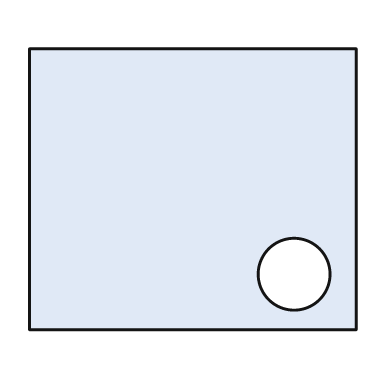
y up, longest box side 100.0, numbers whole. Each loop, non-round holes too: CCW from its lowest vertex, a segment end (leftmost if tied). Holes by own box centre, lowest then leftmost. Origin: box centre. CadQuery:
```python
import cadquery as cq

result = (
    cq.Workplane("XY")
    .moveTo(-50.0, -43.0)
    .lineTo(50.0, -43.0)
    .lineTo(50.0, 43.0)
    .lineTo(-50.0, 43.0)
    .close()
    .moveTo(31.0, -26.0)
    .circle(11.0)
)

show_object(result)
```